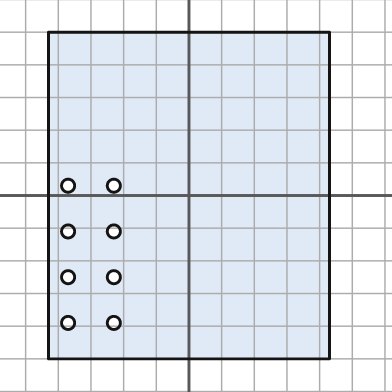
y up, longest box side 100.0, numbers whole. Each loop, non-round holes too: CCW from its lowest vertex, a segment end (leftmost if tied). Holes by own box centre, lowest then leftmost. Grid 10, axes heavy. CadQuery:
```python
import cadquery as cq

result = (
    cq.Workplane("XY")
    .moveTo(-43.0, -50.0)
    .lineTo(43.0, -50.0)
    .lineTo(43.0, 50.0)
    .lineTo(-43.0, 50.0)
    .close()
    .moveTo(-37.0, -39.0)
    .circle(2.0)
    .moveTo(-23.0, -39.0)
    .circle(2.0)
    .moveTo(-37.0, -25.0)
    .circle(2.0)
    .moveTo(-23.0, -25.0)
    .circle(2.0)
    .moveTo(-37.0, -11.0)
    .circle(2.0)
    .moveTo(-23.0, -11.0)
    .circle(2.0)
    .moveTo(-37.0, 3.0)
    .circle(2.0)
    .moveTo(-23.0, 3.0)
    .circle(2.0)
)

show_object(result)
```